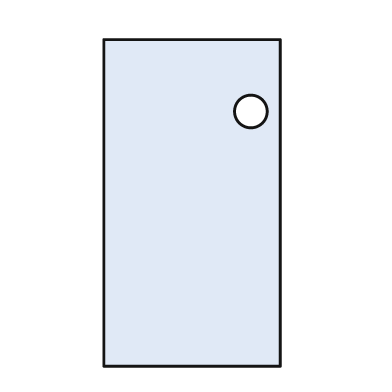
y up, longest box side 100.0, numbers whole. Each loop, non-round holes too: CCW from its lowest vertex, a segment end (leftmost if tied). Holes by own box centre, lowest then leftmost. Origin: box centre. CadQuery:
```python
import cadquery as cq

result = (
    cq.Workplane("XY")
    .moveTo(-27.0, -50.0)
    .lineTo(27.0, -50.0)
    .lineTo(27.0, 50.0)
    .lineTo(-27.0, 50.0)
    .close()
    .moveTo(18.0, 28.0)
    .circle(5.0)
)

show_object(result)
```